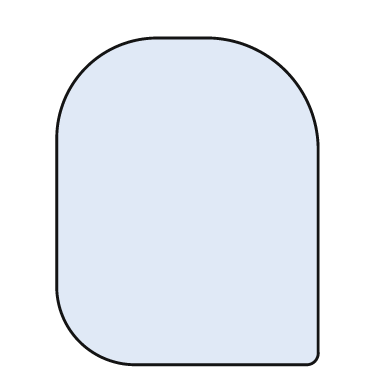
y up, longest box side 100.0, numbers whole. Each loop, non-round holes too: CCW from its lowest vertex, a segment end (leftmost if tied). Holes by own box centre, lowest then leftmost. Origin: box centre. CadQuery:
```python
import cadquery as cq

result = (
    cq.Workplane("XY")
    .moveTo(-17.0, -50.0)
    .lineTo(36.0, -50.0)
    .threePointArc((39.0, -49.0), (40.0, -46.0))
    .lineTo(40.0, 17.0)
    .threePointArc((30.0, 40.0), (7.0, 50.0))
    .lineTo(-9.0, 50.0)
    .threePointArc((-31.0, 41.0), (-40.0, 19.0))
    .lineTo(-40.0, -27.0)
    .threePointArc((-33.0, -43.0), (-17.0, -50.0))
    .close()
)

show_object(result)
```